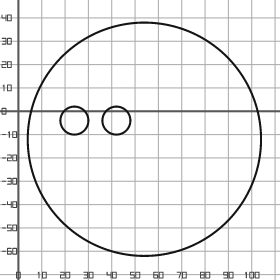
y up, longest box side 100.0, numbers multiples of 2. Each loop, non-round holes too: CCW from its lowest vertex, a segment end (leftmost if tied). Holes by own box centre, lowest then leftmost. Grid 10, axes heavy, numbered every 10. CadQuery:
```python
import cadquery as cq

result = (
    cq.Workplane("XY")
    .moveTo(54.0, -12.0)
    .circle(50.0)
    .moveTo(24.0, -4.0)
    .circle(6.0)
    .moveTo(42.0, -4.0)
    .circle(6.0)
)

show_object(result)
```